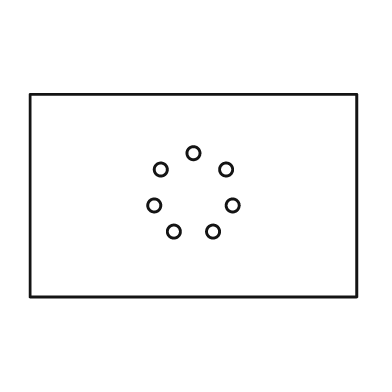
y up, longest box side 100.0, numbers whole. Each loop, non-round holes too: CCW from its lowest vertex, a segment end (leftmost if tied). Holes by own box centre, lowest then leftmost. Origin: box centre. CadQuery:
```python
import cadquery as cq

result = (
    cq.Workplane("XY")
    .moveTo(-50.0, -31.0)
    .lineTo(50.0, -31.0)
    .lineTo(50.0, 31.0)
    .lineTo(-50.0, 31.0)
    .close()
    .moveTo(-6.0, -11.0)
    .circle(2.0)
    .moveTo(6.0, -11.0)
    .circle(2.0)
    .moveTo(-12.0, -3.0)
    .circle(2.0)
    .moveTo(12.0, -3.0)
    .circle(2.0)
    .moveTo(-10.0, 8.0)
    .circle(2.0)
    .moveTo(10.0, 8.0)
    .circle(2.0)
    .moveTo(0.0, 13.0)
    .circle(2.0)
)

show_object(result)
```